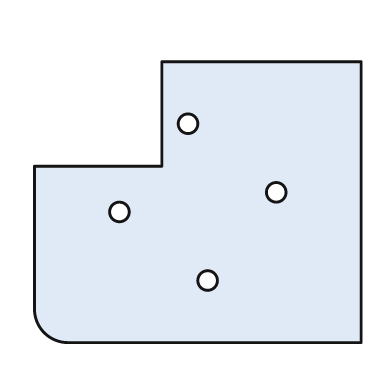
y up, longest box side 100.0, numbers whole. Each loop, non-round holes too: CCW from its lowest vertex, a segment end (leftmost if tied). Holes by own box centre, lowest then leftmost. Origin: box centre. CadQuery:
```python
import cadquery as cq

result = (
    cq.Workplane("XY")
    .moveTo(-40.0, -43.0)
    .lineTo(50.0, -43.0)
    .lineTo(50.0, 43.0)
    .lineTo(-11.0, 43.0)
    .lineTo(-11.0, 11.0)
    .lineTo(-50.0, 11.0)
    .lineTo(-50.0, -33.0)
    .threePointArc((-47.0, -40.0), (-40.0, -43.0))
    .close()
    .moveTo(3.0, -24.0)
    .circle(3.0)
    .moveTo(-24.0, -3.0)
    .circle(3.0)
    .moveTo(24.0, 3.0)
    .circle(3.0)
    .moveTo(-3.0, 24.0)
    .circle(3.0)
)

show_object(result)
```